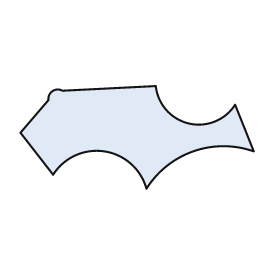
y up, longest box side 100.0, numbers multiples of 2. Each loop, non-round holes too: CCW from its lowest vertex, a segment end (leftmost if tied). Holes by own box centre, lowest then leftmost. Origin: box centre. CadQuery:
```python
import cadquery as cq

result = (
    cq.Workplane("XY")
    .moveTo(4.0, -22.0)
    .threePointArc((24.0, -6.0), (50.0, -6.0))
    .lineTo(42.0, 14.0)
    .threePointArc((22.0, 6.0), (8.0, 22.0))
    .lineTo(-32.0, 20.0)
    .threePointArc((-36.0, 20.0), (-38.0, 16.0))
    .lineTo(-50.0, 2.0)
    .lineTo(-36.0, -16.0)
    .threePointArc((-14.0, -6.0), (4.0, -22.0))
    .close()
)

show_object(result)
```